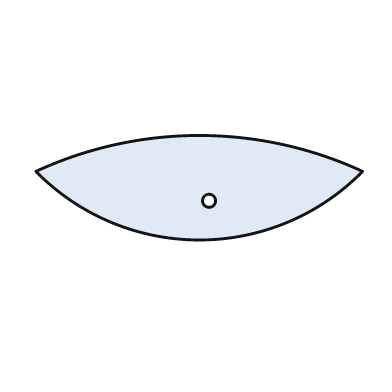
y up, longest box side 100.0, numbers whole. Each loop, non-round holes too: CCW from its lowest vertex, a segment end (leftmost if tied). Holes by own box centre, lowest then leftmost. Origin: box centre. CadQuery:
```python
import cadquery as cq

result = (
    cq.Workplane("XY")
    .moveTo(-50.0, 5.0)
    .threePointArc((0.0, -16.0), (50.0, 5.0))
    .threePointArc((0.0, 16.0), (-50.0, 5.0))
    .close()
    .moveTo(3.0, -4.0)
    .circle(2.0)
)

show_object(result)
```